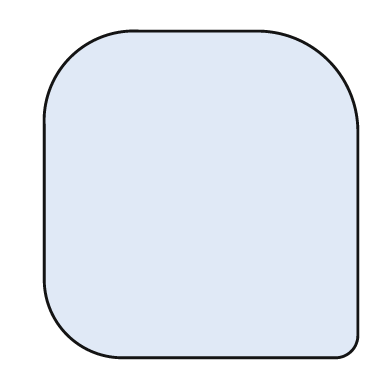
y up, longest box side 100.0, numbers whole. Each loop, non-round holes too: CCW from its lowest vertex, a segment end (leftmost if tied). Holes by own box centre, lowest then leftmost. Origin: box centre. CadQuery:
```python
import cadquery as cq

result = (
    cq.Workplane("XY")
    .moveTo(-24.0, -50.0)
    .lineTo(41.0, -50.0)
    .threePointArc((46.0, -48.0), (48.0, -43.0))
    .lineTo(48.0, 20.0)
    .threePointArc((39.0, 41.0), (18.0, 50.0))
    .lineTo(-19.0, 50.0)
    .threePointArc((-40.0, 42.0), (-48.0, 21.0))
    .lineTo(-48.0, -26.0)
    .threePointArc((-41.0, -43.0), (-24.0, -50.0))
    .close()
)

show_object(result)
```